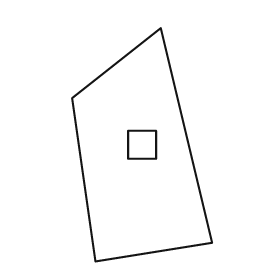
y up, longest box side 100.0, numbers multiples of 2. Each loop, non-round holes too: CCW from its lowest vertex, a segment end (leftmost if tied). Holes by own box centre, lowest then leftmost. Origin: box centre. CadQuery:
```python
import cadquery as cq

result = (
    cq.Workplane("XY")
    .moveTo(-20.0, -50.0)
    .lineTo(30.0, -42.0)
    .lineTo(8.0, 50.0)
    .lineTo(-30.0, 20.0)
    .close()
    .moveTo(-6.0, -6.0)
    .lineTo(6.0, -6.0)
    .lineTo(6.0, 6.0)
    .lineTo(-6.0, 6.0)
    .close()
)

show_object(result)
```